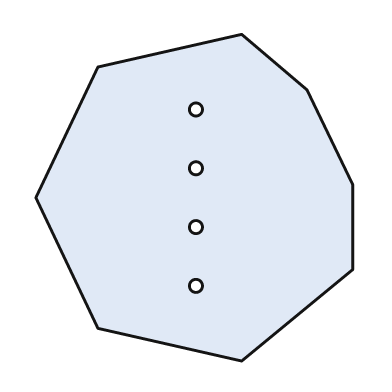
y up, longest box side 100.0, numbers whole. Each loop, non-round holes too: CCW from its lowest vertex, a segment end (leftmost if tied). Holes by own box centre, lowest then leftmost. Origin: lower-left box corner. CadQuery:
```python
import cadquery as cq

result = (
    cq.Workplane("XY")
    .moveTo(63.0, 0.0)
    .lineTo(97.0, 28.0)
    .lineTo(97.0, 54.0)
    .lineTo(83.0, 83.0)
    .lineTo(63.0, 100.0)
    .lineTo(19.0, 90.0)
    .lineTo(0.0, 50.0)
    .lineTo(19.0, 10.0)
    .close()
    .moveTo(49.0, 23.0)
    .circle(2.0)
    .moveTo(49.0, 41.0)
    .circle(2.0)
    .moveTo(49.0, 59.0)
    .circle(2.0)
    .moveTo(49.0, 77.0)
    .circle(2.0)
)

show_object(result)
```